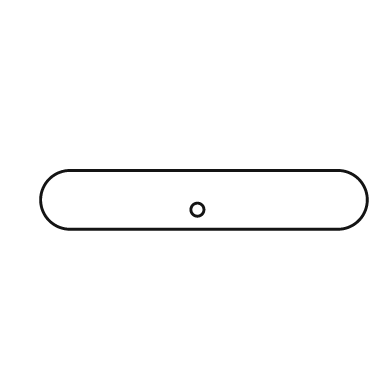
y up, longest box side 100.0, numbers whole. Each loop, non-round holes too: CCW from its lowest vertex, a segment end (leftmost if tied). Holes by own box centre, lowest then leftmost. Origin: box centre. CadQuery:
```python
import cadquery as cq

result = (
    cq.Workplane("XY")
    .moveTo(-41.0, -9.0)
    .lineTo(41.0, -9.0)
    .threePointArc((50.0, 0.0), (41.0, 9.0))
    .lineTo(-41.0, 9.0)
    .threePointArc((-50.0, 0.0), (-41.0, -9.0))
    .close()
    .moveTo(-2.0, -3.0)
    .circle(2.0)
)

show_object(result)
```